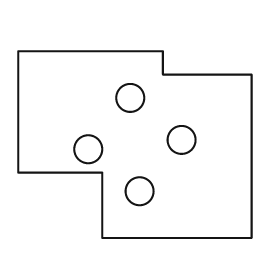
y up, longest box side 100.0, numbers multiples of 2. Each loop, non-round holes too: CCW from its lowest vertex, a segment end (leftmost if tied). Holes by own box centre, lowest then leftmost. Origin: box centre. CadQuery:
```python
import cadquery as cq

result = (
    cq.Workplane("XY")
    .moveTo(-14.0, -40.0)
    .lineTo(50.0, -40.0)
    .lineTo(50.0, 30.0)
    .lineTo(12.0, 30.0)
    .lineTo(12.0, 40.0)
    .lineTo(-50.0, 40.0)
    .lineTo(-50.0, -12.0)
    .lineTo(-14.0, -12.0)
    .close()
    .moveTo(2.0, -20.0)
    .circle(6.0)
    .moveTo(-20.0, -2.0)
    .circle(6.0)
    .moveTo(20.0, 2.0)
    .circle(6.0)
    .moveTo(-2.0, 20.0)
    .circle(6.0)
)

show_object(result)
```